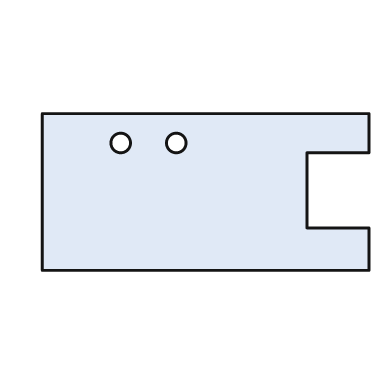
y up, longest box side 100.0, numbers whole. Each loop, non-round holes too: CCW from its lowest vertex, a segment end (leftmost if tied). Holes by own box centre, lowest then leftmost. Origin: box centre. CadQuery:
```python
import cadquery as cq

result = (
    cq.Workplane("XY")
    .moveTo(-50.0, -24.0)
    .lineTo(50.0, -24.0)
    .lineTo(50.0, -11.0)
    .lineTo(31.0, -11.0)
    .lineTo(31.0, 12.0)
    .lineTo(50.0, 12.0)
    .lineTo(50.0, 24.0)
    .lineTo(-50.0, 24.0)
    .close()
    .moveTo(-26.0, 15.0)
    .circle(3.0)
    .moveTo(-9.0, 15.0)
    .circle(3.0)
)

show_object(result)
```